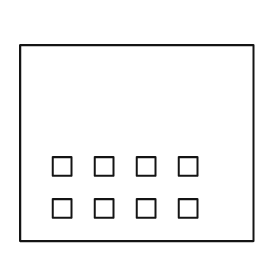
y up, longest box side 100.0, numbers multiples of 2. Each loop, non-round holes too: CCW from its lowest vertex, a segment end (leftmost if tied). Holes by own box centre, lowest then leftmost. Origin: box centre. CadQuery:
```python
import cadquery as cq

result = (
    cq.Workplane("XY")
    .moveTo(-50.0, -42.0)
    .lineTo(50.0, -42.0)
    .lineTo(50.0, 42.0)
    .lineTo(-50.0, 42.0)
    .close()
    .moveTo(-36.0, -32.0)
    .lineTo(-28.0, -32.0)
    .lineTo(-28.0, -24.0)
    .lineTo(-36.0, -24.0)
    .close()
    .moveTo(-18.0, -32.0)
    .lineTo(-10.0, -32.0)
    .lineTo(-10.0, -24.0)
    .lineTo(-18.0, -24.0)
    .close()
    .moveTo(0.0, -32.0)
    .lineTo(8.0, -32.0)
    .lineTo(8.0, -24.0)
    .lineTo(0.0, -24.0)
    .close()
    .moveTo(18.0, -32.0)
    .lineTo(26.0, -32.0)
    .lineTo(26.0, -24.0)
    .lineTo(18.0, -24.0)
    .close()
    .moveTo(-36.0, -14.0)
    .lineTo(-28.0, -14.0)
    .lineTo(-28.0, -6.0)
    .lineTo(-36.0, -6.0)
    .close()
    .moveTo(-18.0, -14.0)
    .lineTo(-10.0, -14.0)
    .lineTo(-10.0, -6.0)
    .lineTo(-18.0, -6.0)
    .close()
    .moveTo(0.0, -14.0)
    .lineTo(8.0, -14.0)
    .lineTo(8.0, -6.0)
    .lineTo(0.0, -6.0)
    .close()
    .moveTo(18.0, -14.0)
    .lineTo(26.0, -14.0)
    .lineTo(26.0, -6.0)
    .lineTo(18.0, -6.0)
    .close()
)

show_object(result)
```